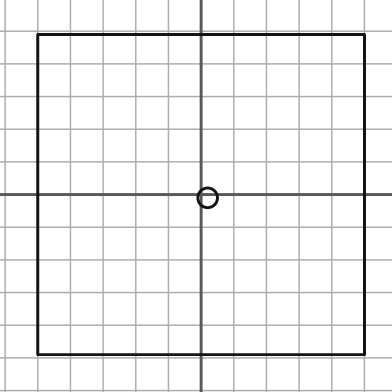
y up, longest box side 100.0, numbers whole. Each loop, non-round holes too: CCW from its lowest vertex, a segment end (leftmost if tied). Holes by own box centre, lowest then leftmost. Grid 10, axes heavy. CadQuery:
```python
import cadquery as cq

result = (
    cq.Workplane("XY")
    .moveTo(-50.0, -49.0)
    .lineTo(50.0, -49.0)
    .lineTo(50.0, 49.0)
    .lineTo(-50.0, 49.0)
    .close()
    .moveTo(2.0, -1.0)
    .circle(3.0)
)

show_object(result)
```